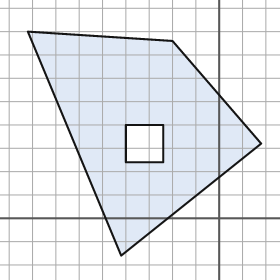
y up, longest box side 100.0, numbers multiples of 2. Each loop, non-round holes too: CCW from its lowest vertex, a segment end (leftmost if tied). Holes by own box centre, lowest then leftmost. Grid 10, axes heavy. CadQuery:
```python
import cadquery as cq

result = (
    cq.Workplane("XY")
    .moveTo(-42.0, -16.0)
    .lineTo(18.0, 32.0)
    .lineTo(-20.0, 76.0)
    .lineTo(-82.0, 80.0)
    .close()
    .moveTo(-40.0, 24.0)
    .lineTo(-24.0, 24.0)
    .lineTo(-24.0, 40.0)
    .lineTo(-40.0, 40.0)
    .close()
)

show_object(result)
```